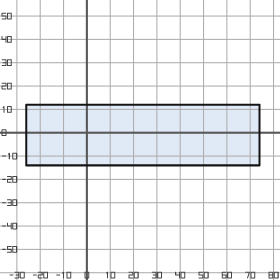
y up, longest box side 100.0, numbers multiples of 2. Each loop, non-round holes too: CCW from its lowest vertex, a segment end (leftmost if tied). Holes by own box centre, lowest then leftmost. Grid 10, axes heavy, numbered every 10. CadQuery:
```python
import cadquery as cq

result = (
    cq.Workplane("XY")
    .moveTo(-26.0, -14.0)
    .lineTo(74.0, -14.0)
    .lineTo(74.0, 12.0)
    .lineTo(-26.0, 12.0)
    .close()
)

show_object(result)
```